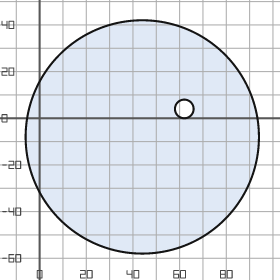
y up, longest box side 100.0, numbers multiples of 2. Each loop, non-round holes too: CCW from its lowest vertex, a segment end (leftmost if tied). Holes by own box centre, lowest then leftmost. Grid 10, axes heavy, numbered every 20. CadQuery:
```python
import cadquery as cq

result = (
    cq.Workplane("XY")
    .moveTo(44.0, -8.0)
    .circle(50.0)
    .moveTo(62.0, 4.0)
    .circle(4.0)
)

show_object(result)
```